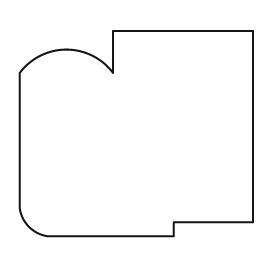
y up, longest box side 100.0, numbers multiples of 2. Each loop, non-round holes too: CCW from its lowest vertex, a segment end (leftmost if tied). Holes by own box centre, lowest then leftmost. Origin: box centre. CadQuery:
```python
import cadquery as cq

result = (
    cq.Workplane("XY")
    .moveTo(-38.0, -44.0)
    .lineTo(16.0, -44.0)
    .lineTo(16.0, -38.0)
    .lineTo(50.0, -38.0)
    .lineTo(50.0, 44.0)
    .lineTo(-10.0, 44.0)
    .lineTo(-10.0, 26.0)
    .threePointArc((-30.0, 36.0), (-50.0, 26.0))
    .lineTo(-50.0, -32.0)
    .threePointArc((-46.0, -40.0), (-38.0, -44.0))
    .close()
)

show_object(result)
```